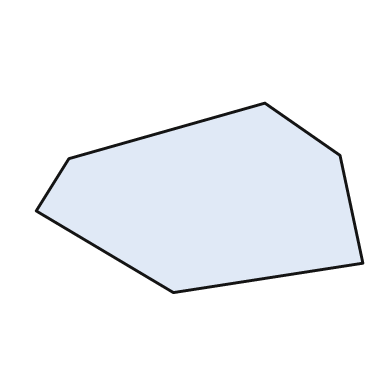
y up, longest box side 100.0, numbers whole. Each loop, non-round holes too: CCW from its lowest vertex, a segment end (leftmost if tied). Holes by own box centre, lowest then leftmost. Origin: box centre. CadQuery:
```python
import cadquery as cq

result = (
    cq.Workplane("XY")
    .moveTo(-8.0, -29.0)
    .lineTo(50.0, -20.0)
    .lineTo(43.0, 13.0)
    .lineTo(20.0, 29.0)
    .lineTo(-40.0, 12.0)
    .lineTo(-50.0, -4.0)
    .close()
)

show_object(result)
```